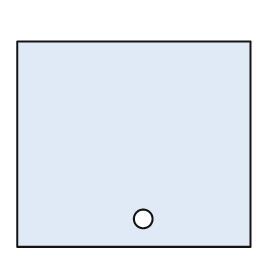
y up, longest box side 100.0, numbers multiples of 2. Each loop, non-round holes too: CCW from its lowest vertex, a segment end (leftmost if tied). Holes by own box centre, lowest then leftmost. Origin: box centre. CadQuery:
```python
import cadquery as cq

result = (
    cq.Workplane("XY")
    .moveTo(-50.0, -44.0)
    .lineTo(50.0, -44.0)
    .lineTo(50.0, 44.0)
    .lineTo(-50.0, 44.0)
    .close()
    .moveTo(4.0, -32.0)
    .circle(4.0)
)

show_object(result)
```